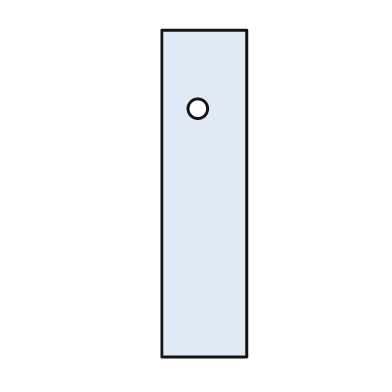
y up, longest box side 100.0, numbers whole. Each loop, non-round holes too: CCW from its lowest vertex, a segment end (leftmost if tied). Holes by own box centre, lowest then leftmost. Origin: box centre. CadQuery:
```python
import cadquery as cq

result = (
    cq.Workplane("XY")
    .moveTo(-13.0, -50.0)
    .lineTo(13.0, -50.0)
    .lineTo(13.0, 50.0)
    .lineTo(-13.0, 50.0)
    .close()
    .moveTo(-2.0, 26.0)
    .circle(3.0)
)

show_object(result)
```